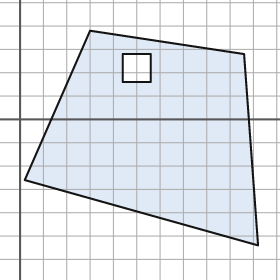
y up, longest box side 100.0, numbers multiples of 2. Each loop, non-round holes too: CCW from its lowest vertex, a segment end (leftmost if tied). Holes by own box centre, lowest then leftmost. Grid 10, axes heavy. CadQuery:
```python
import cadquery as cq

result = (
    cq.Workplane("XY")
    .moveTo(102.0, -54.0)
    .lineTo(96.0, 28.0)
    .lineTo(30.0, 38.0)
    .lineTo(2.0, -26.0)
    .close()
    .moveTo(44.0, 16.0)
    .lineTo(56.0, 16.0)
    .lineTo(56.0, 28.0)
    .lineTo(44.0, 28.0)
    .close()
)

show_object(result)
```